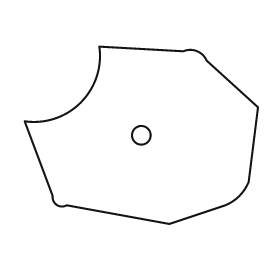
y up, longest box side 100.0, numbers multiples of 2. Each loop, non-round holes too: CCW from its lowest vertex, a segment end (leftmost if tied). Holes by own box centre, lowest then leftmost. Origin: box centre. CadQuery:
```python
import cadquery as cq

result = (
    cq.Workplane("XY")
    .moveTo(12.0, -38.0)
    .lineTo(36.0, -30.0)
    .threePointArc((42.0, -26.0), (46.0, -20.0))
    .lineTo(50.0, 12.0)
    .lineTo(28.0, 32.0)
    .threePointArc((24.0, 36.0), (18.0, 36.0))
    .lineTo(-18.0, 38.0)
    .threePointArc((-26.0, 14.0), (-50.0, 6.0))
    .lineTo(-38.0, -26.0)
    .threePointArc((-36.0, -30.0), (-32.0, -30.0))
    .close()
    .moveTo(0.0, 0.0)
    .circle(4.0)
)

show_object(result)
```